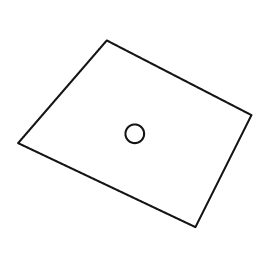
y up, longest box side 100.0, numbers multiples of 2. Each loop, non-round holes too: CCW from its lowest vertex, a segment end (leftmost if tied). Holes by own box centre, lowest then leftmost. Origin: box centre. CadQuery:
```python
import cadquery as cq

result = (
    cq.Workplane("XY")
    .moveTo(26.0, -40.0)
    .lineTo(50.0, 8.0)
    .lineTo(-12.0, 40.0)
    .lineTo(-50.0, -4.0)
    .close()
    .moveTo(0.0, 0.0)
    .circle(4.0)
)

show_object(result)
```